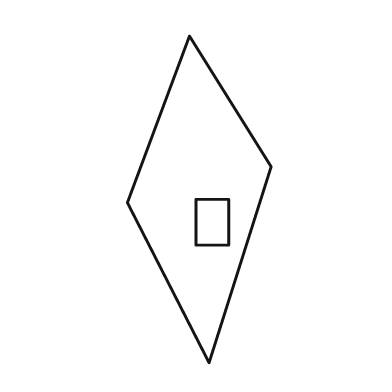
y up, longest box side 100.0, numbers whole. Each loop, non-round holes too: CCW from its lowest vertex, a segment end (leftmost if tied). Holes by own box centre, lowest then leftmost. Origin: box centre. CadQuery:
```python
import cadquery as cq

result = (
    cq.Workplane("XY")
    .moveTo(3.0, -50.0)
    .lineTo(22.0, 10.0)
    .lineTo(-3.0, 50.0)
    .lineTo(-22.0, -1.0)
    .close()
    .moveTo(-1.0, -14.0)
    .lineTo(9.0, -14.0)
    .lineTo(9.0, 0.0)
    .lineTo(-1.0, 0.0)
    .close()
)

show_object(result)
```